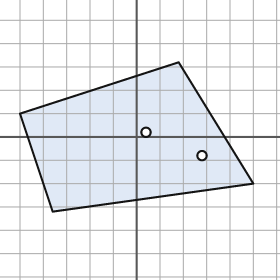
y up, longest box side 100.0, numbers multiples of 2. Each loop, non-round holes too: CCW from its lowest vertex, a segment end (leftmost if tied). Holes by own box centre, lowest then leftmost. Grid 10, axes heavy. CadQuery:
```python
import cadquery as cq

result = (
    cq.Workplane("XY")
    .moveTo(-36.0, -32.0)
    .lineTo(50.0, -20.0)
    .lineTo(18.0, 32.0)
    .lineTo(-50.0, 10.0)
    .close()
    .moveTo(28.0, -8.0)
    .circle(2.0)
    .moveTo(4.0, 2.0)
    .circle(2.0)
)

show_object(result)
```